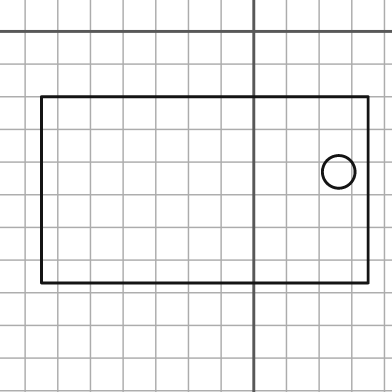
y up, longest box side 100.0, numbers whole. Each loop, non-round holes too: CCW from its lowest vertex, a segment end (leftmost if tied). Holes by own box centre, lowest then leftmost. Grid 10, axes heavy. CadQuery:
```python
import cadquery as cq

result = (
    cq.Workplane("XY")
    .moveTo(-65.0, -77.0)
    .lineTo(35.0, -77.0)
    .lineTo(35.0, -20.0)
    .lineTo(-65.0, -20.0)
    .close()
    .moveTo(26.0, -43.0)
    .circle(5.0)
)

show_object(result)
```